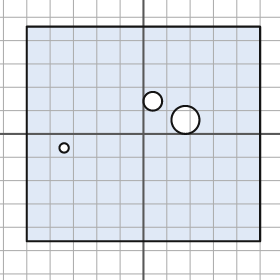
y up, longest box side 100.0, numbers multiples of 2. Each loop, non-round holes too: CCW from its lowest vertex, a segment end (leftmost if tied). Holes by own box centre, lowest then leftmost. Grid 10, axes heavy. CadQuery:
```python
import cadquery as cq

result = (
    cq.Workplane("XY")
    .moveTo(-50.0, -46.0)
    .lineTo(50.0, -46.0)
    .lineTo(50.0, 46.0)
    .lineTo(-50.0, 46.0)
    .close()
    .moveTo(-34.0, -6.0)
    .circle(2.0)
    .moveTo(18.0, 6.0)
    .circle(6.0)
    .moveTo(4.0, 14.0)
    .circle(4.0)
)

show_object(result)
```